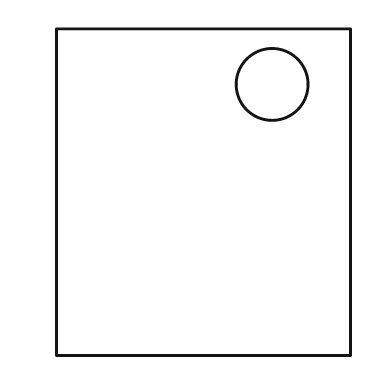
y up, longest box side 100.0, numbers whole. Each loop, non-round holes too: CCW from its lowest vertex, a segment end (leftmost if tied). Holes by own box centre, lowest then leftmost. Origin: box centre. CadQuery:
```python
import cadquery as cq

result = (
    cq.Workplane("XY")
    .moveTo(-45.0, -50.0)
    .lineTo(45.0, -50.0)
    .lineTo(45.0, 50.0)
    .lineTo(-45.0, 50.0)
    .close()
    .moveTo(21.0, 33.0)
    .circle(11.0)
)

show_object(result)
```